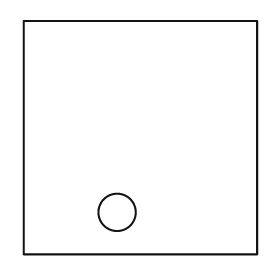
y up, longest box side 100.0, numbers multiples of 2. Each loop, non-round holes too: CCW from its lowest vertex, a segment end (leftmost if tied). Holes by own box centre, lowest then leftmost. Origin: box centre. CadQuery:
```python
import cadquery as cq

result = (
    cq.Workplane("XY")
    .moveTo(-50.0, -50.0)
    .lineTo(50.0, -50.0)
    .lineTo(50.0, 50.0)
    .lineTo(-50.0, 50.0)
    .close()
    .moveTo(-10.0, -32.0)
    .circle(8.0)
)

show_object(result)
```